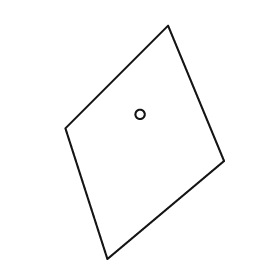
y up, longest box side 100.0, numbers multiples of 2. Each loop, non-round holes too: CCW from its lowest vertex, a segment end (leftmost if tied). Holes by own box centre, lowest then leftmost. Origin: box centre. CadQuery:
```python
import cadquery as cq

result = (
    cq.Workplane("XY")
    .moveTo(-16.0, -50.0)
    .lineTo(34.0, -8.0)
    .lineTo(10.0, 50.0)
    .lineTo(-34.0, 6.0)
    .close()
    .moveTo(-2.0, 12.0)
    .circle(2.0)
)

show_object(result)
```